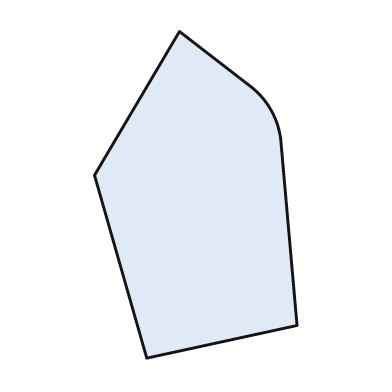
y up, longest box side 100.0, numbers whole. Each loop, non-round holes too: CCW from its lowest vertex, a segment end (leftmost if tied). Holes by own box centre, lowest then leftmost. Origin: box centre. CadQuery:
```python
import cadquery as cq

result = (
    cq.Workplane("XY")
    .moveTo(-15.0, -50.0)
    .lineTo(31.0, -40.0)
    .lineTo(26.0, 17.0)
    .threePointArc((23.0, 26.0), (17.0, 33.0))
    .lineTo(-5.0, 50.0)
    .lineTo(-31.0, 6.0)
    .close()
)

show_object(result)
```